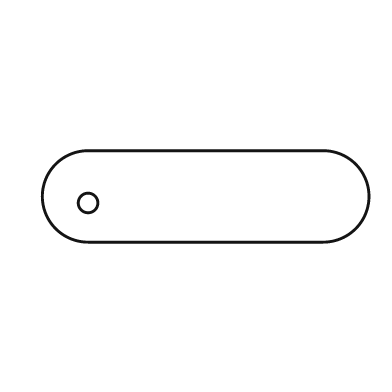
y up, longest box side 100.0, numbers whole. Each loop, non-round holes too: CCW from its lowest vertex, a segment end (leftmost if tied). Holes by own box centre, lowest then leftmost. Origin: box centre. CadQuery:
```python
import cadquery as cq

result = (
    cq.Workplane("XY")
    .moveTo(-36.0, -14.0)
    .lineTo(36.0, -14.0)
    .threePointArc((50.0, 0.0), (36.0, 14.0))
    .lineTo(-36.0, 14.0)
    .threePointArc((-50.0, 0.0), (-36.0, -14.0))
    .close()
    .moveTo(-36.0, -2.0)
    .circle(3.0)
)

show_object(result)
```